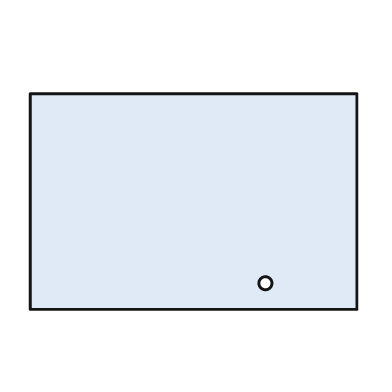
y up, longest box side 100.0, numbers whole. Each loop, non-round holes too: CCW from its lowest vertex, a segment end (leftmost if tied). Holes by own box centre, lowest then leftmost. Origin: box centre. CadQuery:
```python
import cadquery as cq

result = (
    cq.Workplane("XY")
    .moveTo(-50.0, -33.0)
    .lineTo(50.0, -33.0)
    .lineTo(50.0, 33.0)
    .lineTo(-50.0, 33.0)
    .close()
    .moveTo(22.0, -25.0)
    .circle(2.0)
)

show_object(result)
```